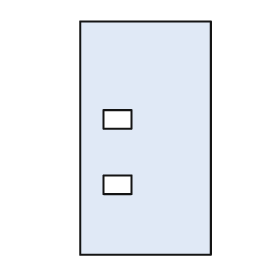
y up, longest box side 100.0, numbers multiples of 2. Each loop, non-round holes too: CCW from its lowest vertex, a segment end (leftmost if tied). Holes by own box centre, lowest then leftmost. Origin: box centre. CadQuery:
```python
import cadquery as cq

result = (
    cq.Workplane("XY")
    .moveTo(-28.0, -50.0)
    .lineTo(28.0, -50.0)
    .lineTo(28.0, 50.0)
    .lineTo(-28.0, 50.0)
    .close()
    .moveTo(-18.0, -24.0)
    .lineTo(-6.0, -24.0)
    .lineTo(-6.0, -16.0)
    .lineTo(-18.0, -16.0)
    .close()
    .moveTo(-18.0, 4.0)
    .lineTo(-6.0, 4.0)
    .lineTo(-6.0, 12.0)
    .lineTo(-18.0, 12.0)
    .close()
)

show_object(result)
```